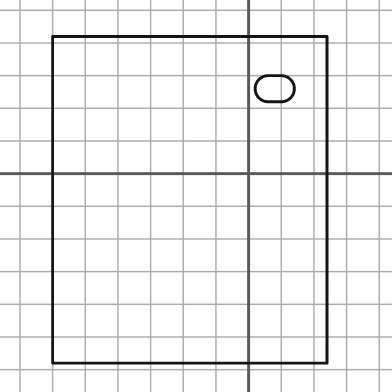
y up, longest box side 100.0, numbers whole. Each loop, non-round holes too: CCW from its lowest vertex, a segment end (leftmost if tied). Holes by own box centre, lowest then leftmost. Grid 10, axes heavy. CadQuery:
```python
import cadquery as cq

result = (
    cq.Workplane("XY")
    .moveTo(-60.0, -58.0)
    .lineTo(24.0, -58.0)
    .lineTo(24.0, 42.0)
    .lineTo(-60.0, 42.0)
    .close()
    .moveTo(6.0, 22.0)
    .lineTo(10.0, 22.0)
    .threePointArc((14.0, 26.0), (10.0, 30.0))
    .lineTo(6.0, 30.0)
    .threePointArc((2.0, 26.0), (6.0, 22.0))
    .close()
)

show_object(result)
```